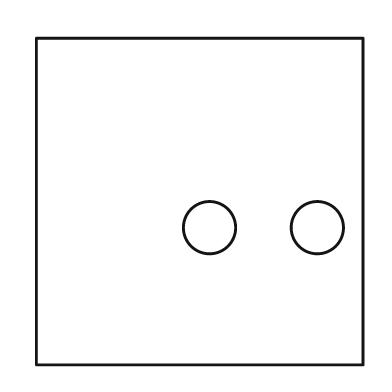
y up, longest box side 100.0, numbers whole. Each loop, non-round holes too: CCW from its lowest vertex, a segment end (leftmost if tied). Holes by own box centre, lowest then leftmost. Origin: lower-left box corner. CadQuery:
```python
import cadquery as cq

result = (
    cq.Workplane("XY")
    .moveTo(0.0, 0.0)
    .lineTo(100.0, 0.0)
    .lineTo(100.0, 100.0)
    .lineTo(0.0, 100.0)
    .close()
    .moveTo(53.0, 42.0)
    .circle(8.0)
    .moveTo(86.0, 42.0)
    .circle(8.0)
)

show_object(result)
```